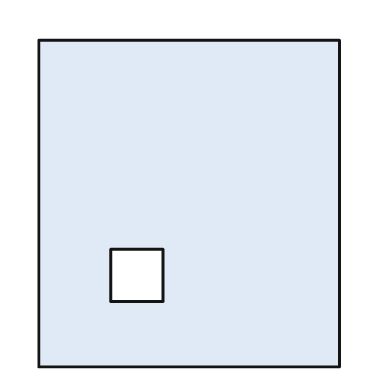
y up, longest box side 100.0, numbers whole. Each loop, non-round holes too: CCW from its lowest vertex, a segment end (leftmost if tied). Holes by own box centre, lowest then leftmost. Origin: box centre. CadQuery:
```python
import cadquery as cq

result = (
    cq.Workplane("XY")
    .moveTo(-46.0, -50.0)
    .lineTo(46.0, -50.0)
    .lineTo(46.0, 50.0)
    .lineTo(-46.0, 50.0)
    .close()
    .moveTo(-24.0, -30.0)
    .lineTo(-8.0, -30.0)
    .lineTo(-8.0, -14.0)
    .lineTo(-24.0, -14.0)
    .close()
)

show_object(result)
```